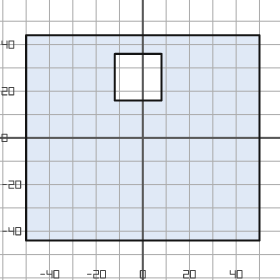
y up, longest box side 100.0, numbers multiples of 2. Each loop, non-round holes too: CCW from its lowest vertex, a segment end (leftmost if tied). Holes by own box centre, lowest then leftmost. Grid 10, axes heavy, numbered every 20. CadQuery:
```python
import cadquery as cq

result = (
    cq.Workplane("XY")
    .moveTo(-50.0, -44.0)
    .lineTo(50.0, -44.0)
    .lineTo(50.0, 44.0)
    .lineTo(-50.0, 44.0)
    .close()
    .moveTo(-12.0, 16.0)
    .lineTo(8.0, 16.0)
    .lineTo(8.0, 36.0)
    .lineTo(-12.0, 36.0)
    .close()
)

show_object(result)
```